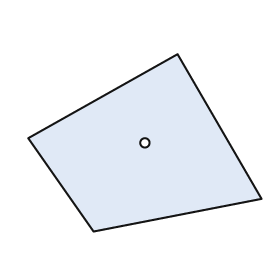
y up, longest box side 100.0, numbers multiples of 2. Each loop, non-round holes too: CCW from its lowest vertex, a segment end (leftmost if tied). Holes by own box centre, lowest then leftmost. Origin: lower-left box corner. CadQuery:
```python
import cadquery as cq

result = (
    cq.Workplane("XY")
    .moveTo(28.0, 0.0)
    .lineTo(100.0, 14.0)
    .lineTo(64.0, 76.0)
    .lineTo(0.0, 40.0)
    .close()
    .moveTo(50.0, 38.0)
    .circle(2.0)
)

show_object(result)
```